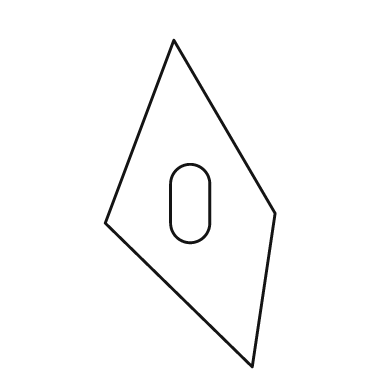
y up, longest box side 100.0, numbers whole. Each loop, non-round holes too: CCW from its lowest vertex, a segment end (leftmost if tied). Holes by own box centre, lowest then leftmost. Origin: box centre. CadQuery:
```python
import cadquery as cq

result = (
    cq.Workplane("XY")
    .moveTo(19.0, -50.0)
    .lineTo(26.0, -3.0)
    .lineTo(-5.0, 50.0)
    .lineTo(-26.0, -6.0)
    .close()
    .moveTo(-6.0, -6.0)
    .threePointArc((0.0, -12.0), (6.0, -6.0))
    .lineTo(6.0, 6.0)
    .threePointArc((0.0, 12.0), (-6.0, 6.0))
    .close()
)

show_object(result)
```